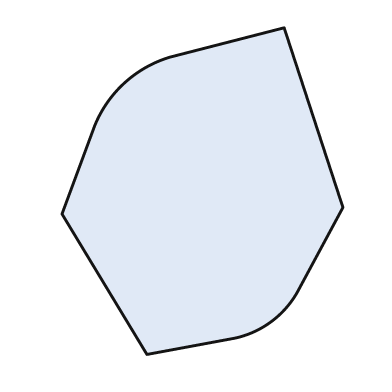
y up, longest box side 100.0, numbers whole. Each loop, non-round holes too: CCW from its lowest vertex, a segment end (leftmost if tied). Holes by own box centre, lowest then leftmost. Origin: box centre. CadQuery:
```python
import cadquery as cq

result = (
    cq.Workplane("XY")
    .moveTo(-17.0, -50.0)
    .lineTo(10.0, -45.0)
    .threePointArc((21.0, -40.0), (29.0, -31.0))
    .lineTo(43.0, -5.0)
    .lineTo(25.0, 50.0)
    .lineTo(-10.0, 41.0)
    .threePointArc((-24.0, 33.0), (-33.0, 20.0))
    .lineTo(-43.0, -7.0)
    .close()
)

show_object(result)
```